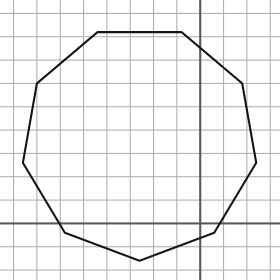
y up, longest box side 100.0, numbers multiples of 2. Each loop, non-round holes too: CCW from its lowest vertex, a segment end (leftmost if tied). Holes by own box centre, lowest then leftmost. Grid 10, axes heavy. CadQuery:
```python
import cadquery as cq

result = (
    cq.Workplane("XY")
    .moveTo(-26.0, -16.0)
    .lineTo(6.0, -4.0)
    .lineTo(24.0, 26.0)
    .lineTo(18.0, 60.0)
    .lineTo(-8.0, 82.0)
    .lineTo(-44.0, 82.0)
    .lineTo(-70.0, 60.0)
    .lineTo(-76.0, 26.0)
    .lineTo(-58.0, -4.0)
    .close()
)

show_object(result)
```